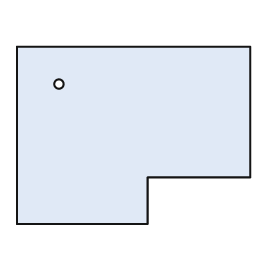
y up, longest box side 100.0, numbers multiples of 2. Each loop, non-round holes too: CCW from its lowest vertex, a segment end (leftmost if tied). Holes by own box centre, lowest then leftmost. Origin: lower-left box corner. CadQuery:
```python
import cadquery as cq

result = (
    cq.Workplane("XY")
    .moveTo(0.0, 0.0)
    .lineTo(56.0, 0.0)
    .lineTo(56.0, 20.0)
    .lineTo(100.0, 20.0)
    .lineTo(100.0, 76.0)
    .lineTo(0.0, 76.0)
    .close()
    .moveTo(18.0, 60.0)
    .circle(2.0)
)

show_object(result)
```